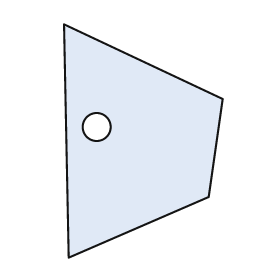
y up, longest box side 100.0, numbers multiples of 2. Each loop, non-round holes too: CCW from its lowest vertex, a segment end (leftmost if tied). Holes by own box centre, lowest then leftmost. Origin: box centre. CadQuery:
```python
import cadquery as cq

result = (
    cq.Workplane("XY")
    .moveTo(-32.0, -50.0)
    .lineTo(28.0, -24.0)
    .lineTo(34.0, 18.0)
    .lineTo(-34.0, 50.0)
    .close()
    .moveTo(-20.0, 6.0)
    .circle(6.0)
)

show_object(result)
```